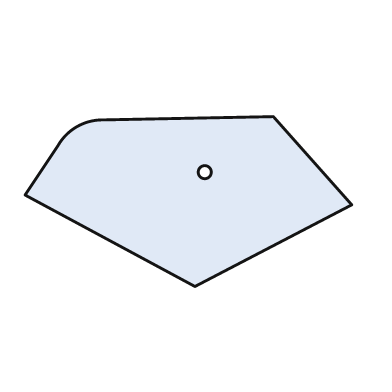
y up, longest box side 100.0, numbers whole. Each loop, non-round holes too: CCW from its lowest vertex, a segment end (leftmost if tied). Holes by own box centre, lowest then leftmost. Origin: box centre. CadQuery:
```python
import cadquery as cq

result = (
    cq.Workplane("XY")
    .moveTo(2.0, -26.0)
    .lineTo(50.0, -1.0)
    .lineTo(26.0, 26.0)
    .lineTo(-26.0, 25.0)
    .threePointArc((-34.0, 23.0), (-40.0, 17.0))
    .lineTo(-50.0, 2.0)
    .close()
    .moveTo(5.0, 9.0)
    .circle(2.0)
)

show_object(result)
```